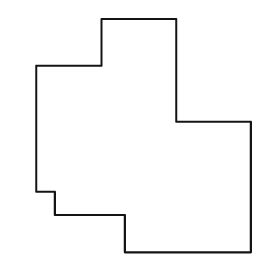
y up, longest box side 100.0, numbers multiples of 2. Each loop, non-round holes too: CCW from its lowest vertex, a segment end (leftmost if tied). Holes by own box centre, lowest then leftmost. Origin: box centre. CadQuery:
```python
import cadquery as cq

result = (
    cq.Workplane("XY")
    .moveTo(-8.0, -50.0)
    .lineTo(46.0, -50.0)
    .lineTo(46.0, 6.0)
    .lineTo(14.0, 6.0)
    .lineTo(14.0, 50.0)
    .lineTo(-18.0, 50.0)
    .lineTo(-18.0, 30.0)
    .lineTo(-46.0, 30.0)
    .lineTo(-46.0, -24.0)
    .lineTo(-38.0, -24.0)
    .lineTo(-38.0, -34.0)
    .lineTo(-8.0, -34.0)
    .close()
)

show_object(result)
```